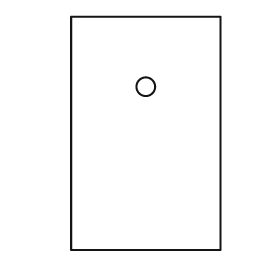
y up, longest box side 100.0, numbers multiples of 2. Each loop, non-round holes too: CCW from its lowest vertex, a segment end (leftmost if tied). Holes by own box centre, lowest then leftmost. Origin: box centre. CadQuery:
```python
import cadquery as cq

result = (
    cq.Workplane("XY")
    .moveTo(-32.0, -50.0)
    .lineTo(32.0, -50.0)
    .lineTo(32.0, 50.0)
    .lineTo(-32.0, 50.0)
    .close()
    .moveTo(0.0, 20.0)
    .circle(4.0)
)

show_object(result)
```